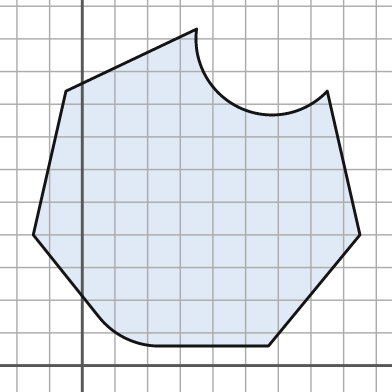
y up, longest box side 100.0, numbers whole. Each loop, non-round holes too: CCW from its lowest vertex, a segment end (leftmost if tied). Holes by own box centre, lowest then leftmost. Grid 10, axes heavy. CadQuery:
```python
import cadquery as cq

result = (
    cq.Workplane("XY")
    .moveTo(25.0, 6.0)
    .lineTo(57.0, 6.0)
    .lineTo(85.0, 40.0)
    .lineTo(75.0, 84.0)
    .threePointArc((48.0, 79.0), (35.0, 103.0))
    .lineTo(-5.0, 84.0)
    .lineTo(-15.0, 40.0)
    .lineTo(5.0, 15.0)
    .threePointArc((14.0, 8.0), (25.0, 6.0))
    .close()
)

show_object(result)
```